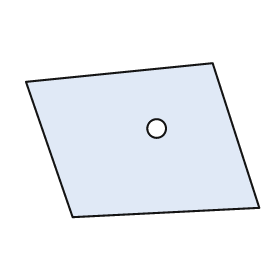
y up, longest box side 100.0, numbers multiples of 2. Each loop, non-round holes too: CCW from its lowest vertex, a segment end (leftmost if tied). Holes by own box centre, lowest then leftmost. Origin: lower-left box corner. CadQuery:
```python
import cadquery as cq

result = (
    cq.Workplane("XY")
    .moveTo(20.0, 0.0)
    .lineTo(100.0, 4.0)
    .lineTo(80.0, 66.0)
    .lineTo(0.0, 58.0)
    .close()
    .moveTo(56.0, 38.0)
    .circle(4.0)
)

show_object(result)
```